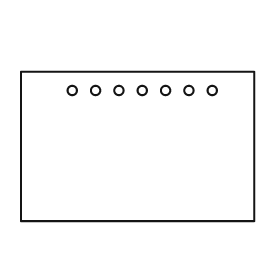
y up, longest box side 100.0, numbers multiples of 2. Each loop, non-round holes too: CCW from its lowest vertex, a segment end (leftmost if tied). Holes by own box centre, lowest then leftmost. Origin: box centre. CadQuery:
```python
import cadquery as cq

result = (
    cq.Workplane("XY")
    .moveTo(-50.0, -32.0)
    .lineTo(50.0, -32.0)
    .lineTo(50.0, 32.0)
    .lineTo(-50.0, 32.0)
    .close()
    .moveTo(-28.0, 24.0)
    .circle(2.0)
    .moveTo(-18.0, 24.0)
    .circle(2.0)
    .moveTo(-8.0, 24.0)
    .circle(2.0)
    .moveTo(2.0, 24.0)
    .circle(2.0)
    .moveTo(12.0, 24.0)
    .circle(2.0)
    .moveTo(22.0, 24.0)
    .circle(2.0)
    .moveTo(32.0, 24.0)
    .circle(2.0)
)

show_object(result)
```